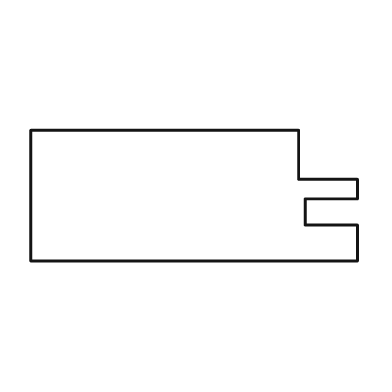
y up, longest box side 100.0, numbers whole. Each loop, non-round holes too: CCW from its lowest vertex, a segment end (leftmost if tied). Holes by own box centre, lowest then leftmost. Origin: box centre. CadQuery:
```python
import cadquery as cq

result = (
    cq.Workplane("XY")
    .moveTo(-50.0, -20.0)
    .lineTo(50.0, -20.0)
    .lineTo(50.0, -9.0)
    .lineTo(34.0, -9.0)
    .lineTo(34.0, -1.0)
    .lineTo(50.0, -1.0)
    .lineTo(50.0, 5.0)
    .lineTo(32.0, 5.0)
    .lineTo(32.0, 20.0)
    .lineTo(-50.0, 20.0)
    .close()
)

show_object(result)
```